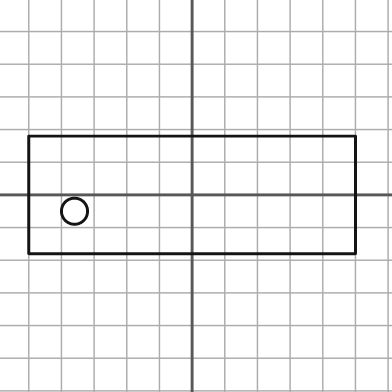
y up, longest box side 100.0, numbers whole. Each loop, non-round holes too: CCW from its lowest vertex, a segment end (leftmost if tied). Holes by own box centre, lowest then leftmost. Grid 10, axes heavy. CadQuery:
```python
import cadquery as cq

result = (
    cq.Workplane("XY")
    .moveTo(-50.0, -18.0)
    .lineTo(50.0, -18.0)
    .lineTo(50.0, 18.0)
    .lineTo(-50.0, 18.0)
    .close()
    .moveTo(-36.0, -5.0)
    .circle(4.0)
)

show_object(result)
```